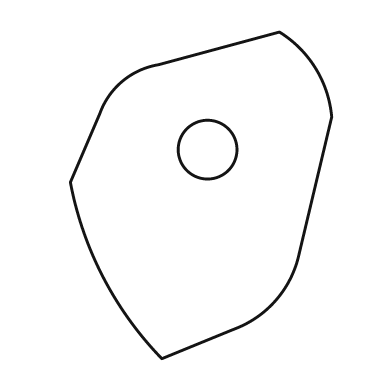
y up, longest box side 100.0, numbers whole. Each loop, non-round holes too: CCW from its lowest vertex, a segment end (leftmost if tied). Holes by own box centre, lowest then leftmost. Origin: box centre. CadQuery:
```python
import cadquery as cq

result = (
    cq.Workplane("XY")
    .moveTo(-12.0, -50.0)
    .lineTo(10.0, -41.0)
    .threePointArc((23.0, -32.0), (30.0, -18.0))
    .lineTo(40.0, 24.0)
    .threePointArc((35.0, 39.0), (24.0, 50.0))
    .lineTo(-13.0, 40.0)
    .threePointArc((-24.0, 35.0), (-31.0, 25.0))
    .lineTo(-40.0, 4.0)
    .threePointArc((-30.0, -25.0), (-12.0, -50.0))
    .close()
    .moveTo(2.0, 14.0)
    .circle(9.0)
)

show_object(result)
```